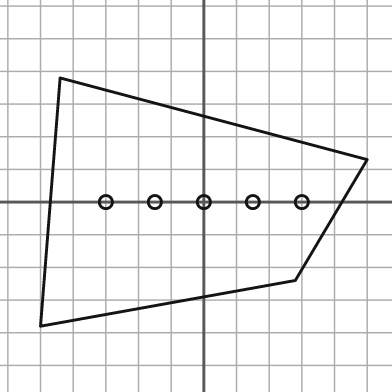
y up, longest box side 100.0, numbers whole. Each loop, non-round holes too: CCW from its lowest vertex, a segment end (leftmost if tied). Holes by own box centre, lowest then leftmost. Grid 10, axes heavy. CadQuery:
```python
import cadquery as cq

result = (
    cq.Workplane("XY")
    .moveTo(-50.0, -38.0)
    .lineTo(28.0, -24.0)
    .lineTo(50.0, 13.0)
    .lineTo(-44.0, 38.0)
    .close()
    .moveTo(-30.0, 0.0)
    .circle(2.0)
    .moveTo(-15.0, 0.0)
    .circle(2.0)
    .moveTo(0.0, 0.0)
    .circle(2.0)
    .moveTo(15.0, 0.0)
    .circle(2.0)
    .moveTo(30.0, 0.0)
    .circle(2.0)
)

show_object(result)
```